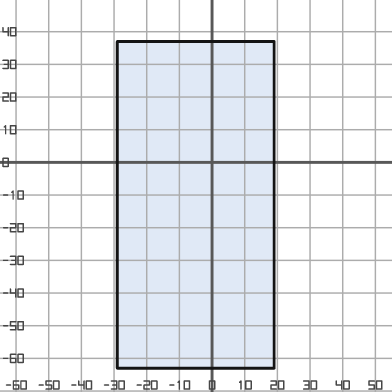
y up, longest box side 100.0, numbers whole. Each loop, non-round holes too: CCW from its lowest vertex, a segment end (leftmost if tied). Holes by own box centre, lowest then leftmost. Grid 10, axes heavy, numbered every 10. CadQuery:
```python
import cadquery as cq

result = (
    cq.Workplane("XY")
    .moveTo(-29.0, -63.0)
    .lineTo(19.0, -63.0)
    .lineTo(19.0, 37.0)
    .lineTo(-29.0, 37.0)
    .close()
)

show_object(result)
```